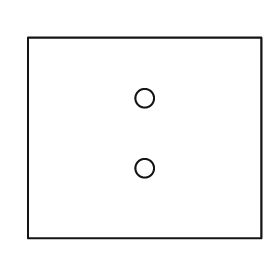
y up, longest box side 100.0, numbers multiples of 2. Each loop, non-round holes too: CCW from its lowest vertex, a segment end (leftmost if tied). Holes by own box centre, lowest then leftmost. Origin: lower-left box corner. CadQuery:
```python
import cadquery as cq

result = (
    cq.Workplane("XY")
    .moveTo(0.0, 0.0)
    .lineTo(100.0, 0.0)
    .lineTo(100.0, 86.0)
    .lineTo(0.0, 86.0)
    .close()
    .moveTo(50.0, 30.0)
    .circle(4.0)
    .moveTo(50.0, 60.0)
    .circle(4.0)
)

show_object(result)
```